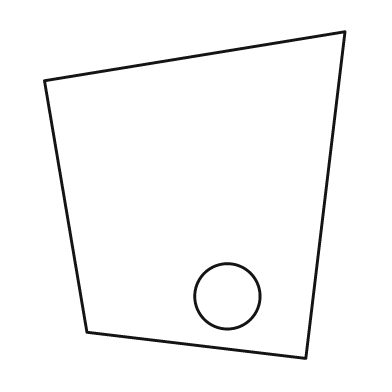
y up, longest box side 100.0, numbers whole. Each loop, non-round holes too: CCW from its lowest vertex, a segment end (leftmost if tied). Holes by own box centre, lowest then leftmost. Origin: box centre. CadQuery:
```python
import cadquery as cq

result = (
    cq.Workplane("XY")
    .moveTo(34.0, -50.0)
    .lineTo(46.0, 50.0)
    .lineTo(-46.0, 35.0)
    .lineTo(-33.0, -42.0)
    .close()
    .moveTo(10.0, -31.0)
    .circle(10.0)
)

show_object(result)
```